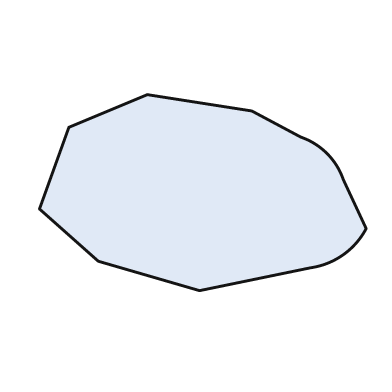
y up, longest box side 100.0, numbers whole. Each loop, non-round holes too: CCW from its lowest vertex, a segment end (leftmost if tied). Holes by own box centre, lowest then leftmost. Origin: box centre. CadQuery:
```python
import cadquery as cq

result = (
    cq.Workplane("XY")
    .moveTo(-1.0, -30.0)
    .lineTo(33.0, -23.0)
    .threePointArc((43.0, -19.0), (50.0, -11.0))
    .lineTo(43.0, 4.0)
    .threePointArc((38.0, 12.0), (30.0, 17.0))
    .lineTo(15.0, 25.0)
    .lineTo(-17.0, 30.0)
    .lineTo(-41.0, 20.0)
    .lineTo(-50.0, -5.0)
    .lineTo(-32.0, -21.0)
    .close()
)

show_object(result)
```